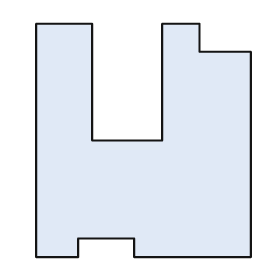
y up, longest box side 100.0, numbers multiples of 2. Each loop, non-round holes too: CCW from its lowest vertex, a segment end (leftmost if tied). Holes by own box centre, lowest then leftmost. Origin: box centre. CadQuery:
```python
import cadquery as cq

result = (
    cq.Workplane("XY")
    .moveTo(-46.0, -50.0)
    .lineTo(-28.0, -50.0)
    .lineTo(-28.0, -42.0)
    .lineTo(-4.0, -42.0)
    .lineTo(-4.0, -50.0)
    .lineTo(46.0, -50.0)
    .lineTo(46.0, 38.0)
    .lineTo(24.0, 38.0)
    .lineTo(24.0, 50.0)
    .lineTo(8.0, 50.0)
    .lineTo(8.0, 0.0)
    .lineTo(-22.0, 0.0)
    .lineTo(-22.0, 50.0)
    .lineTo(-46.0, 50.0)
    .close()
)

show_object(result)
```